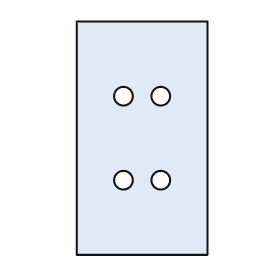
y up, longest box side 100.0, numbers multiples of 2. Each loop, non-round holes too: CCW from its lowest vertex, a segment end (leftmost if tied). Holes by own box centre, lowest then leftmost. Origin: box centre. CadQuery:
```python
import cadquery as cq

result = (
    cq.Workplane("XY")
    .moveTo(-28.0, -50.0)
    .lineTo(28.0, -50.0)
    .lineTo(28.0, 50.0)
    .lineTo(-28.0, 50.0)
    .close()
    .moveTo(-8.0, -18.0)
    .circle(4.0)
    .moveTo(8.0, -18.0)
    .circle(4.0)
    .moveTo(-8.0, 18.0)
    .circle(4.0)
    .moveTo(8.0, 18.0)
    .circle(4.0)
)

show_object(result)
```